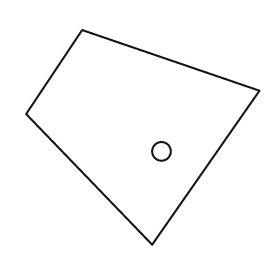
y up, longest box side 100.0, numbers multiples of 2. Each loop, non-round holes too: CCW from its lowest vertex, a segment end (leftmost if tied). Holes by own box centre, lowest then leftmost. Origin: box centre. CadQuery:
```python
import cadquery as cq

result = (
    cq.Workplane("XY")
    .moveTo(4.0, -46.0)
    .lineTo(50.0, 20.0)
    .lineTo(-26.0, 46.0)
    .lineTo(-50.0, 10.0)
    .close()
    .moveTo(8.0, -6.0)
    .circle(4.0)
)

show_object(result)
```